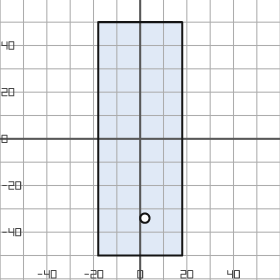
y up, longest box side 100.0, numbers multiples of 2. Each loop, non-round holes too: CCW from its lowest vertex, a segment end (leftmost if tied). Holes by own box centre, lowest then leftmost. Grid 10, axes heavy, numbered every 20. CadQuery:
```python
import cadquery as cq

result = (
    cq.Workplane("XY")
    .moveTo(-18.0, -50.0)
    .lineTo(18.0, -50.0)
    .lineTo(18.0, 50.0)
    .lineTo(-18.0, 50.0)
    .close()
    .moveTo(2.0, -34.0)
    .circle(2.0)
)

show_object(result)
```